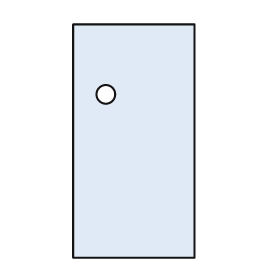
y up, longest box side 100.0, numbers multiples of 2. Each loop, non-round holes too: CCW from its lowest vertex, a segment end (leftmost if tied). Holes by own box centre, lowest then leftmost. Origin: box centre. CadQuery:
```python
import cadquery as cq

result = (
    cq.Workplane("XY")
    .moveTo(-26.0, -50.0)
    .lineTo(26.0, -50.0)
    .lineTo(26.0, 50.0)
    .lineTo(-26.0, 50.0)
    .close()
    .moveTo(-12.0, 20.0)
    .circle(4.0)
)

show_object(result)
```